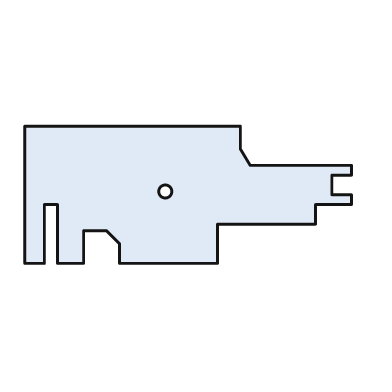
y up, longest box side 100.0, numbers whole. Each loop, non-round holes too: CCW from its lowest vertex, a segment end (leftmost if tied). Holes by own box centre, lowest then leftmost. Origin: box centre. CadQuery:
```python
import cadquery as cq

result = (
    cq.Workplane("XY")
    .moveTo(-50.0, -21.0)
    .lineTo(-44.0, -21.0)
    .lineTo(-44.0, -3.0)
    .lineTo(-40.0, -3.0)
    .lineTo(-40.0, -21.0)
    .lineTo(-32.0, -21.0)
    .lineTo(-32.0, -11.0)
    .lineTo(-25.0, -11.0)
    .lineTo(-21.0, -15.0)
    .lineTo(-21.0, -21.0)
    .lineTo(9.0, -21.0)
    .lineTo(9.0, -9.0)
    .lineTo(39.0, -9.0)
    .lineTo(39.0, -3.0)
    .lineTo(50.0, -3.0)
    .lineTo(50.0, 0.0)
    .lineTo(44.0, 0.0)
    .lineTo(44.0, 6.0)
    .lineTo(50.0, 6.0)
    .lineTo(50.0, 9.0)
    .lineTo(19.0, 9.0)
    .lineTo(16.0, 14.0)
    .lineTo(16.0, 21.0)
    .lineTo(-50.0, 21.0)
    .close()
    .moveTo(-7.0, 1.0)
    .circle(2.0)
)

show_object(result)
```